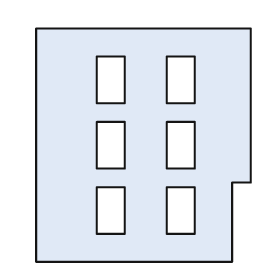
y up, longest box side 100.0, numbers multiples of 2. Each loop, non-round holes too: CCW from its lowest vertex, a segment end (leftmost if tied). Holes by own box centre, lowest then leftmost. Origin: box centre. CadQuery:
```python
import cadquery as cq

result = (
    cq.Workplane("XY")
    .moveTo(-46.0, -50.0)
    .lineTo(38.0, -50.0)
    .lineTo(38.0, -16.0)
    .lineTo(46.0, -16.0)
    .lineTo(46.0, 50.0)
    .lineTo(-46.0, 50.0)
    .close()
    .moveTo(-20.0, -38.0)
    .lineTo(-8.0, -38.0)
    .lineTo(-8.0, -18.0)
    .lineTo(-20.0, -18.0)
    .close()
    .moveTo(10.0, -38.0)
    .lineTo(22.0, -38.0)
    .lineTo(22.0, -18.0)
    .lineTo(10.0, -18.0)
    .close()
    .moveTo(-20.0, -10.0)
    .lineTo(-8.0, -10.0)
    .lineTo(-8.0, 10.0)
    .lineTo(-20.0, 10.0)
    .close()
    .moveTo(10.0, -10.0)
    .lineTo(22.0, -10.0)
    .lineTo(22.0, 10.0)
    .lineTo(10.0, 10.0)
    .close()
    .moveTo(-20.0, 18.0)
    .lineTo(-8.0, 18.0)
    .lineTo(-8.0, 38.0)
    .lineTo(-20.0, 38.0)
    .close()
    .moveTo(10.0, 18.0)
    .lineTo(22.0, 18.0)
    .lineTo(22.0, 38.0)
    .lineTo(10.0, 38.0)
    .close()
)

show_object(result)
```